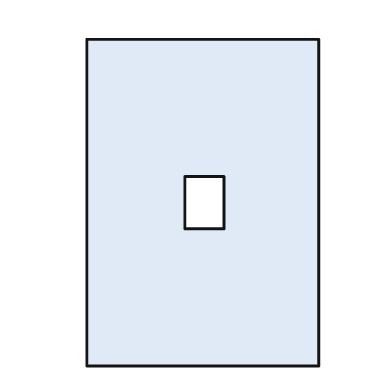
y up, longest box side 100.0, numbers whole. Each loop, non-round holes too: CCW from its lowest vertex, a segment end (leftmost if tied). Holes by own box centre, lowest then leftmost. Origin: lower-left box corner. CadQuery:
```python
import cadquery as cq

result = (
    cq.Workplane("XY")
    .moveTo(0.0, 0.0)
    .lineTo(71.0, 0.0)
    .lineTo(71.0, 100.0)
    .lineTo(0.0, 100.0)
    .close()
    .moveTo(30.0, 42.0)
    .lineTo(42.0, 42.0)
    .lineTo(42.0, 58.0)
    .lineTo(30.0, 58.0)
    .close()
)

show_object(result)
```